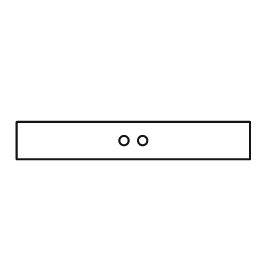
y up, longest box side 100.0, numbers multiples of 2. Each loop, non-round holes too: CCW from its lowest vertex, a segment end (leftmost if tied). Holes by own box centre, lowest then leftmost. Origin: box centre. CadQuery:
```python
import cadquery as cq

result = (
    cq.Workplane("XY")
    .moveTo(-50.0, -8.0)
    .lineTo(50.0, -8.0)
    .lineTo(50.0, 8.0)
    .lineTo(-50.0, 8.0)
    .close()
    .moveTo(-4.0, 0.0)
    .circle(2.0)
    .moveTo(4.0, 0.0)
    .circle(2.0)
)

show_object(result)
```